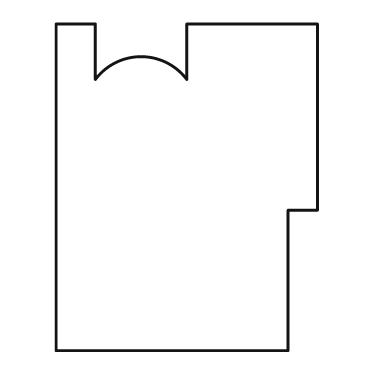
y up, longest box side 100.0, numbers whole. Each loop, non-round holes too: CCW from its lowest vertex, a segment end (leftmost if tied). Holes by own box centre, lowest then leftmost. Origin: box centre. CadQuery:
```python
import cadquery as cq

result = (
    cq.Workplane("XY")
    .moveTo(-40.0, -50.0)
    .lineTo(31.0, -50.0)
    .lineTo(31.0, -7.0)
    .lineTo(40.0, -7.0)
    .lineTo(40.0, 50.0)
    .lineTo(0.0, 50.0)
    .lineTo(0.0, 33.0)
    .threePointArc((-14.0, 40.0), (-28.0, 33.0))
    .lineTo(-28.0, 50.0)
    .lineTo(-40.0, 50.0)
    .close()
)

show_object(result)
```